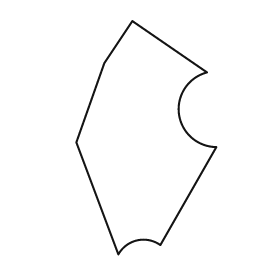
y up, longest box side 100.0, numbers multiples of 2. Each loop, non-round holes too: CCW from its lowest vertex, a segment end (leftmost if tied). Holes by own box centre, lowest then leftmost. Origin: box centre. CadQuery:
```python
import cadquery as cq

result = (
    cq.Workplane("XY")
    .moveTo(-12.0, -50.0)
    .threePointArc((-4.0, -44.0), (6.0, -46.0))
    .lineTo(30.0, -4.0)
    .threePointArc((14.0, 10.0), (26.0, 28.0))
    .lineTo(-6.0, 50.0)
    .lineTo(-18.0, 32.0)
    .lineTo(-30.0, -2.0)
    .close()
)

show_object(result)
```